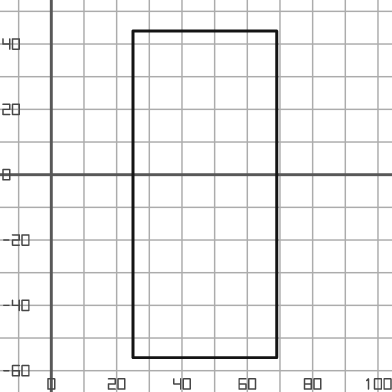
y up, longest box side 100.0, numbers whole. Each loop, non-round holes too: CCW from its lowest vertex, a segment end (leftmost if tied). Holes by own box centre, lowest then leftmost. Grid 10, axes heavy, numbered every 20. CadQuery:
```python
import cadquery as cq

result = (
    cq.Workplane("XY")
    .moveTo(25.0, -56.0)
    .lineTo(69.0, -56.0)
    .lineTo(69.0, 44.0)
    .lineTo(25.0, 44.0)
    .close()
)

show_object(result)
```